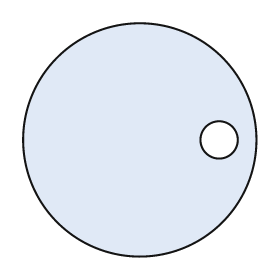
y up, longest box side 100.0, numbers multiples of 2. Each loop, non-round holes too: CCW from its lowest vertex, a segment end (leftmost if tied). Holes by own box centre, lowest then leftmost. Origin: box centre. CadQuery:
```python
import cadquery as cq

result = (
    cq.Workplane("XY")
    .moveTo(0.0, 0.0)
    .circle(50.0)
    .moveTo(34.0, 0.0)
    .circle(8.0)
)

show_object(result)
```